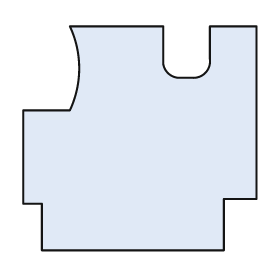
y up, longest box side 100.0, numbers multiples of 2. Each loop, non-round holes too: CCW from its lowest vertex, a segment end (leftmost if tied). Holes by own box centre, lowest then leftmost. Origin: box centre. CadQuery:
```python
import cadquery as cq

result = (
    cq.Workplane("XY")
    .moveTo(-42.0, -48.0)
    .lineTo(36.0, -48.0)
    .lineTo(36.0, -26.0)
    .lineTo(50.0, -26.0)
    .lineTo(50.0, 48.0)
    .lineTo(30.0, 48.0)
    .lineTo(30.0, 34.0)
    .threePointArc((28.0, 28.0), (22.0, 26.0))
    .lineTo(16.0, 26.0)
    .threePointArc((12.0, 28.0), (10.0, 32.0))
    .lineTo(10.0, 48.0)
    .lineTo(-30.0, 48.0)
    .threePointArc((-26.0, 30.0), (-30.0, 12.0))
    .lineTo(-50.0, 12.0)
    .lineTo(-50.0, -28.0)
    .lineTo(-42.0, -28.0)
    .close()
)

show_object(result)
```